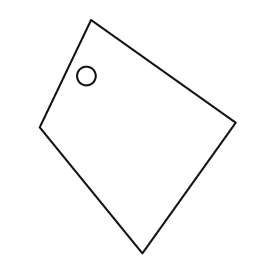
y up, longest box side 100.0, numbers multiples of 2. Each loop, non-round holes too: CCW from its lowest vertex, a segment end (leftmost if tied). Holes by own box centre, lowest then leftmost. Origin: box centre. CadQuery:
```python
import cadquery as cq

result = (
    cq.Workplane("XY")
    .moveTo(2.0, -50.0)
    .lineTo(42.0, 6.0)
    .lineTo(-20.0, 50.0)
    .lineTo(-42.0, 4.0)
    .close()
    .moveTo(-22.0, 26.0)
    .circle(4.0)
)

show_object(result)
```